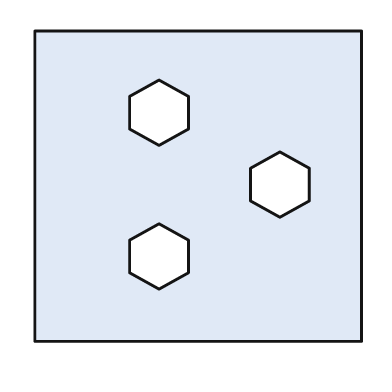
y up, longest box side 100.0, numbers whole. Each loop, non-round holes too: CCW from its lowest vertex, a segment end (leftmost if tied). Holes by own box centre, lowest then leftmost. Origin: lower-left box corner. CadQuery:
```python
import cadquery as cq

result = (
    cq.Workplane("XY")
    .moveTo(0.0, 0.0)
    .lineTo(100.0, 0.0)
    .lineTo(100.0, 95.0)
    .lineTo(0.0, 95.0)
    .close()
    .moveTo(38.0, 16.0)
    .lineTo(47.0, 21.0)
    .lineTo(47.0, 31.0)
    .lineTo(38.0, 36.0)
    .lineTo(29.0, 31.0)
    .lineTo(29.0, 21.0)
    .close()
    .moveTo(75.0, 38.0)
    .lineTo(84.0, 43.0)
    .lineTo(84.0, 53.0)
    .lineTo(75.0, 58.0)
    .lineTo(66.0, 53.0)
    .lineTo(66.0, 43.0)
    .close()
    .moveTo(38.0, 60.0)
    .lineTo(47.0, 65.0)
    .lineTo(47.0, 75.0)
    .lineTo(38.0, 80.0)
    .lineTo(29.0, 75.0)
    .lineTo(29.0, 65.0)
    .close()
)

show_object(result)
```